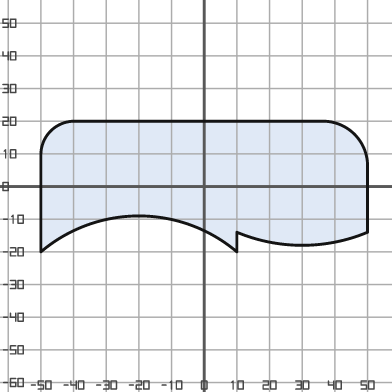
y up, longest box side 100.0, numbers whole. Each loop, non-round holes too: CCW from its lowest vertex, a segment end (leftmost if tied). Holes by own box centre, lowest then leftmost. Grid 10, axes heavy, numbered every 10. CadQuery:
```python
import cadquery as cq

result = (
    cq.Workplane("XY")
    .moveTo(-50.0, -20.0)
    .threePointArc((-20.0, -9.0), (10.0, -20.0))
    .lineTo(10.0, -14.0)
    .threePointArc((30.0, -18.0), (50.0, -14.0))
    .lineTo(50.0, 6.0)
    .threePointArc((46.0, 16.0), (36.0, 20.0))
    .lineTo(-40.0, 20.0)
    .threePointArc((-47.0, 17.0), (-50.0, 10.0))
    .close()
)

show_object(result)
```